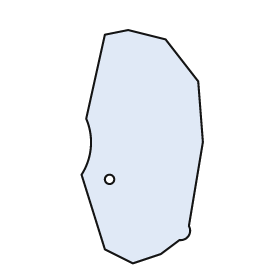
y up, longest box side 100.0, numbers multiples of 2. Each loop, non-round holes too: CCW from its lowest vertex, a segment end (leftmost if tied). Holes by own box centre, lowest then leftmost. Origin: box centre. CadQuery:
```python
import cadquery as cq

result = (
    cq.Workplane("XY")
    .moveTo(-4.0, -50.0)
    .lineTo(8.0, -46.0)
    .lineTo(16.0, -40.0)
    .threePointArc((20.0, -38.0), (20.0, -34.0))
    .lineTo(26.0, 2.0)
    .lineTo(24.0, 28.0)
    .lineTo(10.0, 46.0)
    .lineTo(-6.0, 50.0)
    .lineTo(-16.0, 48.0)
    .lineTo(-24.0, 12.0)
    .threePointArc((-22.0, 0.0), (-26.0, -12.0))
    .lineTo(-16.0, -44.0)
    .close()
    .moveTo(-14.0, -14.0)
    .circle(2.0)
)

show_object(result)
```